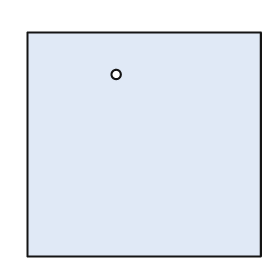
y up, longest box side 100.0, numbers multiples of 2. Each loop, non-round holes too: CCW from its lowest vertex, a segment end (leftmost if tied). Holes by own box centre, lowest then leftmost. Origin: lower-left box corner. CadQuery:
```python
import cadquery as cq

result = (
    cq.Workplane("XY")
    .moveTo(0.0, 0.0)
    .lineTo(100.0, 0.0)
    .lineTo(100.0, 96.0)
    .lineTo(0.0, 96.0)
    .close()
    .moveTo(38.0, 78.0)
    .circle(2.0)
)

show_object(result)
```